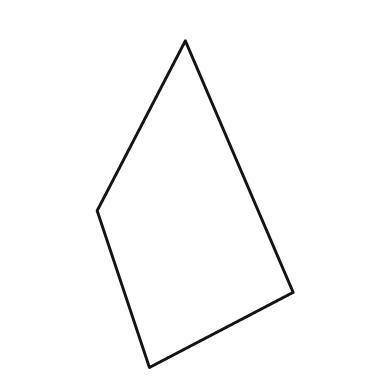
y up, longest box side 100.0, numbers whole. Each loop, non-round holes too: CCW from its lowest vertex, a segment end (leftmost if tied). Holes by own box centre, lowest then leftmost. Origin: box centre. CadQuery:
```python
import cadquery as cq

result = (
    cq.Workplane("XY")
    .moveTo(-14.0, -50.0)
    .lineTo(30.0, -27.0)
    .lineTo(-3.0, 50.0)
    .lineTo(-30.0, -2.0)
    .close()
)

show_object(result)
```